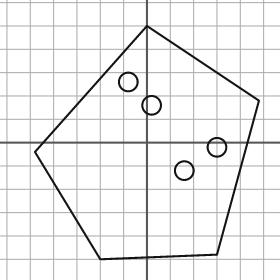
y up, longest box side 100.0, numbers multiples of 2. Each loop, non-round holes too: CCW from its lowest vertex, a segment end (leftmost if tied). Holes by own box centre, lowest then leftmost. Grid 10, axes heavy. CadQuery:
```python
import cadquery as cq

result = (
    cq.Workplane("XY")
    .moveTo(-20.0, -50.0)
    .lineTo(30.0, -48.0)
    .lineTo(48.0, 18.0)
    .lineTo(0.0, 50.0)
    .lineTo(-48.0, -4.0)
    .close()
    .moveTo(16.0, -12.0)
    .circle(4.0)
    .moveTo(30.0, -2.0)
    .circle(4.0)
    .moveTo(2.0, 16.0)
    .circle(4.0)
    .moveTo(-8.0, 26.0)
    .circle(4.0)
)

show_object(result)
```